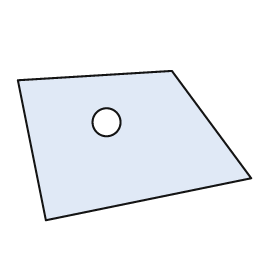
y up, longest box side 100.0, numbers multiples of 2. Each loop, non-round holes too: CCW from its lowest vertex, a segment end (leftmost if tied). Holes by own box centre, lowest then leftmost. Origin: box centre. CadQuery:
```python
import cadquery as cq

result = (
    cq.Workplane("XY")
    .moveTo(-38.0, -32.0)
    .lineTo(50.0, -14.0)
    .lineTo(16.0, 32.0)
    .lineTo(-50.0, 28.0)
    .close()
    .moveTo(-12.0, 10.0)
    .circle(6.0)
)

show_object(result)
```